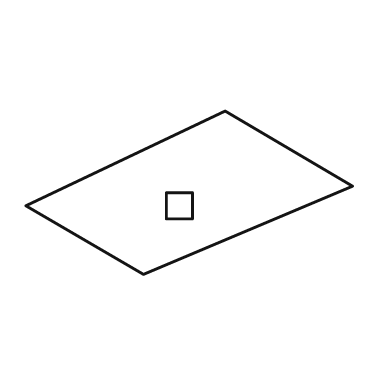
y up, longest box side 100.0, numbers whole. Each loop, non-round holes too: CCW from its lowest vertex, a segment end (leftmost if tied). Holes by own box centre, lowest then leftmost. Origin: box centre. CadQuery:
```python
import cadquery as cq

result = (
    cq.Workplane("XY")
    .moveTo(-14.0, -25.0)
    .lineTo(50.0, 2.0)
    .lineTo(11.0, 25.0)
    .lineTo(-50.0, -4.0)
    .close()
    .moveTo(-7.0, -8.0)
    .lineTo(1.0, -8.0)
    .lineTo(1.0, 0.0)
    .lineTo(-7.0, 0.0)
    .close()
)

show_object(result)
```